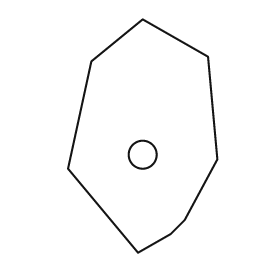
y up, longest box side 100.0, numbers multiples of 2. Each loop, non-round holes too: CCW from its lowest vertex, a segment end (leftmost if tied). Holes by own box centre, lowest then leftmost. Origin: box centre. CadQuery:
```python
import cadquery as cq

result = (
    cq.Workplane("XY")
    .moveTo(-2.0, -50.0)
    .lineTo(12.0, -42.0)
    .lineTo(18.0, -36.0)
    .lineTo(32.0, -10.0)
    .lineTo(28.0, 34.0)
    .lineTo(0.0, 50.0)
    .lineTo(-22.0, 32.0)
    .lineTo(-32.0, -14.0)
    .close()
    .moveTo(0.0, -8.0)
    .circle(6.0)
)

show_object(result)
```